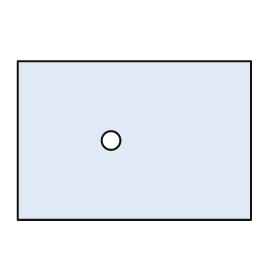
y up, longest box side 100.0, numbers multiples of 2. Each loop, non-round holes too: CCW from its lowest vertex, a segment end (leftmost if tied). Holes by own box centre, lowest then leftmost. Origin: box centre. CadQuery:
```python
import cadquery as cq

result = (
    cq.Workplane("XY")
    .moveTo(-50.0, -34.0)
    .lineTo(50.0, -34.0)
    .lineTo(50.0, 34.0)
    .lineTo(-50.0, 34.0)
    .close()
    .moveTo(-10.0, 0.0)
    .circle(4.0)
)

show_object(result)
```